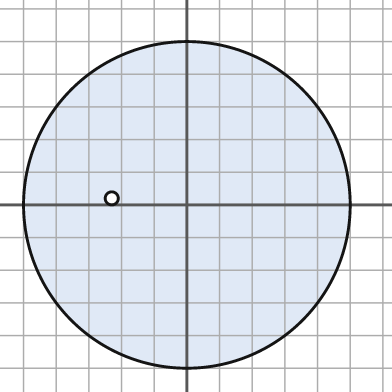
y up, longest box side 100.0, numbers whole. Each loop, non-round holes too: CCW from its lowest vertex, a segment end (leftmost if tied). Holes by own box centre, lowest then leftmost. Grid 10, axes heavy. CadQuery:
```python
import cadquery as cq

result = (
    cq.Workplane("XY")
    .moveTo(0.0, 0.0)
    .circle(50.0)
    .moveTo(-23.0, 2.0)
    .circle(2.0)
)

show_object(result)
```